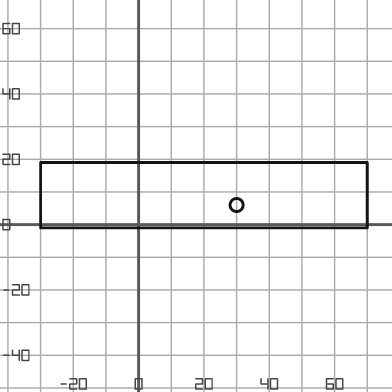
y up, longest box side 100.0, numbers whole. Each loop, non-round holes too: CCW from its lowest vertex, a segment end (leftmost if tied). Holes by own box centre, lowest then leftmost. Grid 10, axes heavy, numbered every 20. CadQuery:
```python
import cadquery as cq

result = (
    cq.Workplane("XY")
    .moveTo(-30.0, -1.0)
    .lineTo(70.0, -1.0)
    .lineTo(70.0, 19.0)
    .lineTo(-30.0, 19.0)
    .close()
    .moveTo(30.0, 6.0)
    .circle(2.0)
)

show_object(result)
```